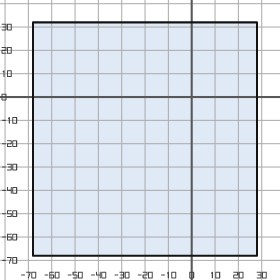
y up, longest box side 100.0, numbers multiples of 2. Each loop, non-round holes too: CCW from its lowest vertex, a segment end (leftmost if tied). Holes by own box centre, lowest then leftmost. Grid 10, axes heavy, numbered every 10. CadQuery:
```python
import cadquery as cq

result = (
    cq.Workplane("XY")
    .moveTo(-68.0, -68.0)
    .lineTo(28.0, -68.0)
    .lineTo(28.0, 32.0)
    .lineTo(-68.0, 32.0)
    .close()
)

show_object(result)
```